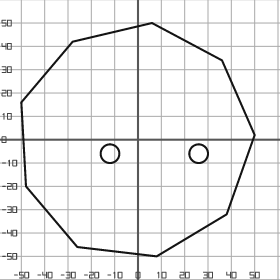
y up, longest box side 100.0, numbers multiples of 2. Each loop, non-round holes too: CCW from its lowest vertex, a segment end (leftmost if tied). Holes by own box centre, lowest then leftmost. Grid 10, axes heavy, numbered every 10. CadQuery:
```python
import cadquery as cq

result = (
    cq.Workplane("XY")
    .moveTo(8.0, -50.0)
    .lineTo(38.0, -32.0)
    .lineTo(50.0, 2.0)
    .lineTo(36.0, 34.0)
    .lineTo(6.0, 50.0)
    .lineTo(-28.0, 42.0)
    .lineTo(-50.0, 16.0)
    .lineTo(-48.0, -20.0)
    .lineTo(-26.0, -46.0)
    .close()
    .moveTo(-12.0, -6.0)
    .circle(4.0)
    .moveTo(26.0, -6.0)
    .circle(4.0)
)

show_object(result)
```